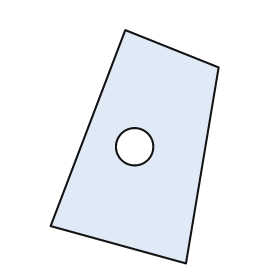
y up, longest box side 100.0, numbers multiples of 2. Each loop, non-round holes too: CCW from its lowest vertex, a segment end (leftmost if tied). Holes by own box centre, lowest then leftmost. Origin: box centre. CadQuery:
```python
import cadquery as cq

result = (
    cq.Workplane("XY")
    .moveTo(22.0, -50.0)
    .lineTo(36.0, 34.0)
    .lineTo(-4.0, 50.0)
    .lineTo(-36.0, -34.0)
    .close()
    .moveTo(0.0, 0.0)
    .circle(8.0)
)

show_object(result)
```